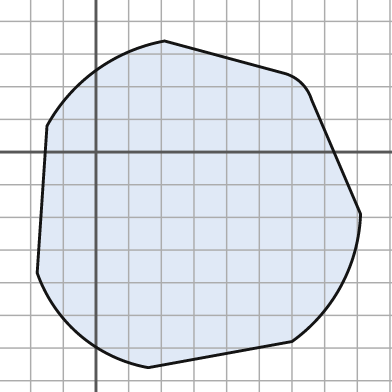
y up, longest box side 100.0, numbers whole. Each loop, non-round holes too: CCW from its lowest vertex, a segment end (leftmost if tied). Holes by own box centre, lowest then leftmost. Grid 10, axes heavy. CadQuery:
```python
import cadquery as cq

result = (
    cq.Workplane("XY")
    .moveTo(16.0, -66.0)
    .lineTo(60.0, -58.0)
    .threePointArc((75.0, -41.0), (81.0, -19.0))
    .lineTo(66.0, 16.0)
    .threePointArc((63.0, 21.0), (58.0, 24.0))
    .lineTo(21.0, 34.0)
    .threePointArc((0.0, 25.0), (-15.0, 8.0))
    .lineTo(-18.0, -37.0)
    .threePointArc((-5.0, -56.0), (16.0, -66.0))
    .close()
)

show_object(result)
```